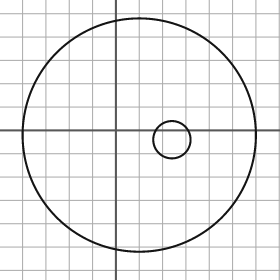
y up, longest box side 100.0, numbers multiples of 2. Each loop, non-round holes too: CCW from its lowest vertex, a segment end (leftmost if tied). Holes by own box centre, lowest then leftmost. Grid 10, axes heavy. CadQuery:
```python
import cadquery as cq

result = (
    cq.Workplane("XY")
    .moveTo(10.0, -2.0)
    .circle(50.0)
    .moveTo(24.0, -4.0)
    .circle(8.0)
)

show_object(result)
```